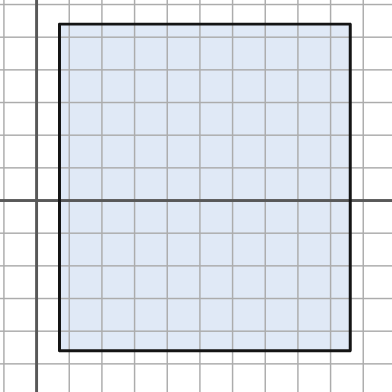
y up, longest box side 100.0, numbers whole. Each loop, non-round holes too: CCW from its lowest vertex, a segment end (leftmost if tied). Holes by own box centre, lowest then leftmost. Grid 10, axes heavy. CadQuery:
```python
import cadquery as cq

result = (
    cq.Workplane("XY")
    .moveTo(7.0, -46.0)
    .lineTo(96.0, -46.0)
    .lineTo(96.0, 54.0)
    .lineTo(7.0, 54.0)
    .close()
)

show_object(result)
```